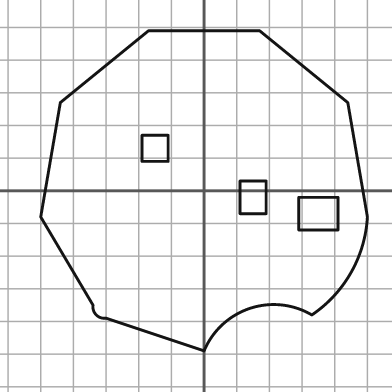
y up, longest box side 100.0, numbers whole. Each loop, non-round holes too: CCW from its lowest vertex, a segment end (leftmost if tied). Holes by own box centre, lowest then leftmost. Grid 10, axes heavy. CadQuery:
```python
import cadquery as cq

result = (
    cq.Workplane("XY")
    .moveTo(0.0, -49.0)
    .threePointArc((14.0, -36.0), (33.0, -38.0))
    .threePointArc((45.0, -25.0), (50.0, -8.0))
    .lineTo(44.0, 27.0)
    .lineTo(17.0, 49.0)
    .lineTo(-17.0, 49.0)
    .lineTo(-44.0, 27.0)
    .lineTo(-50.0, -8.0)
    .lineTo(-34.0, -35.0)
    .threePointArc((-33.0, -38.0), (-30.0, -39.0))
    .close()
    .moveTo(29.0, -12.0)
    .lineTo(41.0, -12.0)
    .lineTo(41.0, -2.0)
    .lineTo(29.0, -2.0)
    .close()
    .moveTo(11.0, -7.0)
    .lineTo(19.0, -7.0)
    .lineTo(19.0, 3.0)
    .lineTo(11.0, 3.0)
    .close()
    .moveTo(-19.0, 9.0)
    .lineTo(-11.0, 9.0)
    .lineTo(-11.0, 17.0)
    .lineTo(-19.0, 17.0)
    .close()
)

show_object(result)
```